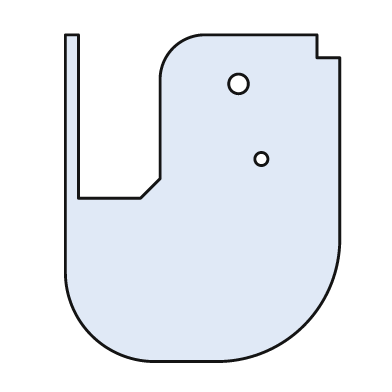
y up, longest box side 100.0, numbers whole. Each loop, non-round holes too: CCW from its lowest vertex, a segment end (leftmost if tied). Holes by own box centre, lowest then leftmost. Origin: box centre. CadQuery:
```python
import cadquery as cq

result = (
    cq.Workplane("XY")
    .moveTo(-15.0, -50.0)
    .lineTo(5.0, -50.0)
    .threePointArc((31.0, -39.0), (42.0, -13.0))
    .lineTo(42.0, 43.0)
    .lineTo(35.0, 43.0)
    .lineTo(35.0, 50.0)
    .lineTo(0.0, 50.0)
    .threePointArc((-9.0, 46.0), (-13.0, 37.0))
    .lineTo(-13.0, 6.0)
    .lineTo(-19.0, 0.0)
    .lineTo(-38.0, 0.0)
    .lineTo(-38.0, 50.0)
    .lineTo(-42.0, 50.0)
    .lineTo(-42.0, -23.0)
    .threePointArc((-34.0, -42.0), (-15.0, -50.0))
    .close()
    .moveTo(18.0, 12.0)
    .circle(2.0)
    .moveTo(11.0, 35.0)
    .circle(3.0)
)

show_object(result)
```